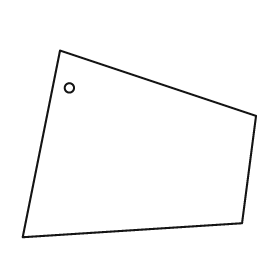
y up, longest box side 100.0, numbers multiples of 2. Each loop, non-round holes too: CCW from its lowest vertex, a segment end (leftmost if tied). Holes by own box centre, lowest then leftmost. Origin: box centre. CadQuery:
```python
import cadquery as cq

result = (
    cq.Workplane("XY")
    .moveTo(-50.0, -40.0)
    .lineTo(44.0, -34.0)
    .lineTo(50.0, 12.0)
    .lineTo(-34.0, 40.0)
    .close()
    .moveTo(-30.0, 24.0)
    .circle(2.0)
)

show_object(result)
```